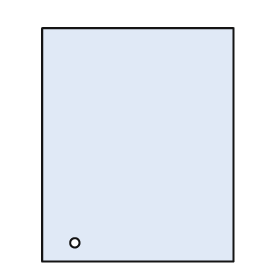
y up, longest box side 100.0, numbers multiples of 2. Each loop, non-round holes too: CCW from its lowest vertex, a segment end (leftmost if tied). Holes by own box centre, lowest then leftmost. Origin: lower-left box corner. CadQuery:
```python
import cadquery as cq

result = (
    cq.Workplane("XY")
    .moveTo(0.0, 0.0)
    .lineTo(82.0, 0.0)
    .lineTo(82.0, 100.0)
    .lineTo(0.0, 100.0)
    .close()
    .moveTo(14.0, 8.0)
    .circle(2.0)
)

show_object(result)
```